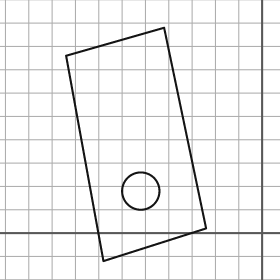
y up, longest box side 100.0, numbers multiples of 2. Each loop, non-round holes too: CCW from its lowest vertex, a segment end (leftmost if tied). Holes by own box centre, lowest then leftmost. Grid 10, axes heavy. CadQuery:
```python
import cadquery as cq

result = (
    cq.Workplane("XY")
    .moveTo(-68.0, -12.0)
    .lineTo(-24.0, 2.0)
    .lineTo(-42.0, 88.0)
    .lineTo(-84.0, 76.0)
    .close()
    .moveTo(-52.0, 18.0)
    .circle(8.0)
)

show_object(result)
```